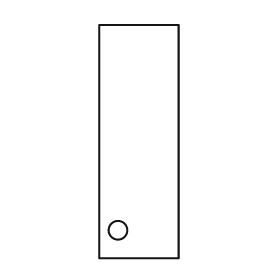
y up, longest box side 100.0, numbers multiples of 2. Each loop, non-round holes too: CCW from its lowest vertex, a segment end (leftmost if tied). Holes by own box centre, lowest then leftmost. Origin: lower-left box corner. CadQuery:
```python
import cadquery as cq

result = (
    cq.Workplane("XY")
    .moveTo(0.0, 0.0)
    .lineTo(34.0, 0.0)
    .lineTo(34.0, 100.0)
    .lineTo(0.0, 100.0)
    .close()
    .moveTo(8.0, 12.0)
    .circle(4.0)
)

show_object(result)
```